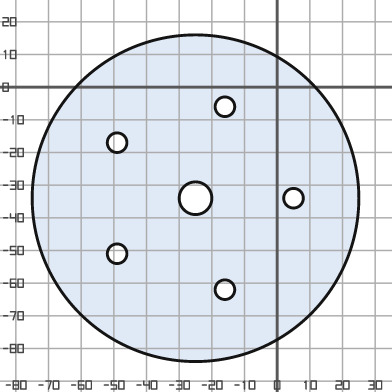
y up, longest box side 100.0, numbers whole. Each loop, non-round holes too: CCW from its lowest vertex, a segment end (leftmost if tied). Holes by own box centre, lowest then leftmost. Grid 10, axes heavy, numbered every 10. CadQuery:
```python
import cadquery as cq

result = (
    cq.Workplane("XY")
    .moveTo(-25.0, -34.0)
    .circle(50.0)
    .moveTo(-16.0, -62.0)
    .circle(3.0)
    .moveTo(-49.0, -51.0)
    .circle(3.0)
    .moveTo(-25.0, -34.0)
    .circle(5.0)
    .moveTo(5.0, -34.0)
    .circle(3.0)
    .moveTo(-49.0, -17.0)
    .circle(3.0)
    .moveTo(-16.0, -6.0)
    .circle(3.0)
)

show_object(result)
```